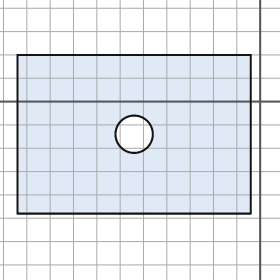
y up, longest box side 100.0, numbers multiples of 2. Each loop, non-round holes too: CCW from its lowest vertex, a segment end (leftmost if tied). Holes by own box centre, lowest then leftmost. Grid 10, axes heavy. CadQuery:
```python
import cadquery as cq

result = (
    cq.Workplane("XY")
    .moveTo(-104.0, -48.0)
    .lineTo(-4.0, -48.0)
    .lineTo(-4.0, 20.0)
    .lineTo(-104.0, 20.0)
    .close()
    .moveTo(-54.0, -14.0)
    .circle(8.0)
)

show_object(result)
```